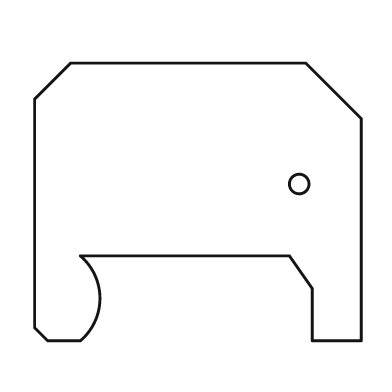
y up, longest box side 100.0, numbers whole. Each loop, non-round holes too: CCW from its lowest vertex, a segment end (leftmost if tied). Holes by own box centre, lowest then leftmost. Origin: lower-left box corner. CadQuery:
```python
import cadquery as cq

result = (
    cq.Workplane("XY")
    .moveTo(4.0, 0.0)
    .lineTo(14.0, 0.0)
    .threePointArc((20.0, 13.0), (14.0, 26.0))
    .lineTo(78.0, 26.0)
    .lineTo(85.0, 16.0)
    .lineTo(85.0, 0.0)
    .lineTo(100.0, 0.0)
    .lineTo(100.0, 68.0)
    .lineTo(83.0, 85.0)
    .lineTo(11.0, 85.0)
    .lineTo(0.0, 74.0)
    .lineTo(0.0, 4.0)
    .close()
    .moveTo(81.0, 48.0)
    .circle(3.0)
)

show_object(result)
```